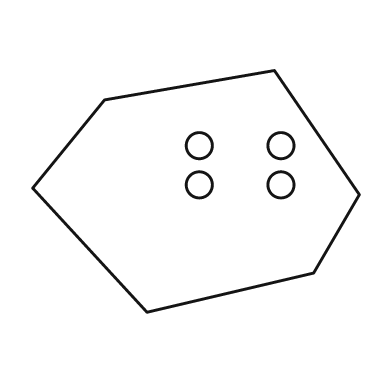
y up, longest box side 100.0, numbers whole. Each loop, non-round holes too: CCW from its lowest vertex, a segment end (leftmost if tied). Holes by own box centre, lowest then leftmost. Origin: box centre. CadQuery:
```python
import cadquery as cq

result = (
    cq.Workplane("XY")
    .moveTo(-15.0, -37.0)
    .lineTo(36.0, -25.0)
    .lineTo(50.0, -1.0)
    .lineTo(24.0, 37.0)
    .lineTo(-28.0, 28.0)
    .lineTo(-50.0, 1.0)
    .close()
    .moveTo(1.0, 2.0)
    .circle(4.0)
    .moveTo(26.0, 2.0)
    .circle(4.0)
    .moveTo(1.0, 14.0)
    .circle(4.0)
    .moveTo(26.0, 14.0)
    .circle(4.0)
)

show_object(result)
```